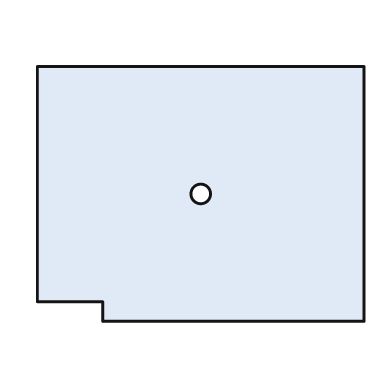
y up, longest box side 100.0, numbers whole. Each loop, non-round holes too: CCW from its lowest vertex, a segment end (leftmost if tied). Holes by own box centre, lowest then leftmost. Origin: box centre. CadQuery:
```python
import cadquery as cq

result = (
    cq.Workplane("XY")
    .moveTo(-30.0, -39.0)
    .lineTo(50.0, -39.0)
    .lineTo(50.0, 39.0)
    .lineTo(-50.0, 39.0)
    .lineTo(-50.0, -33.0)
    .lineTo(-30.0, -33.0)
    .close()
    .moveTo(0.0, 0.0)
    .circle(3.0)
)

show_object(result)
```